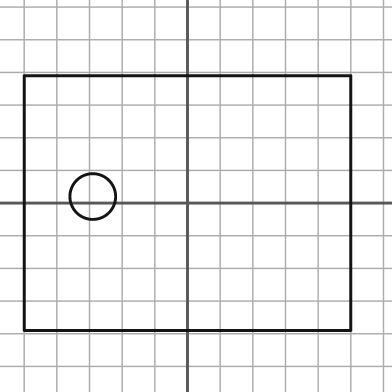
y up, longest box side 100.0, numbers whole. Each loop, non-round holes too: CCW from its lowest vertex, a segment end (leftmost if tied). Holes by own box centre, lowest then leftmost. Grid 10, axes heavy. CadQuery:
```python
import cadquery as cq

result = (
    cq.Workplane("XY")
    .moveTo(-50.0, -39.0)
    .lineTo(50.0, -39.0)
    .lineTo(50.0, 39.0)
    .lineTo(-50.0, 39.0)
    .close()
    .moveTo(-29.0, 2.0)
    .circle(7.0)
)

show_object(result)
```